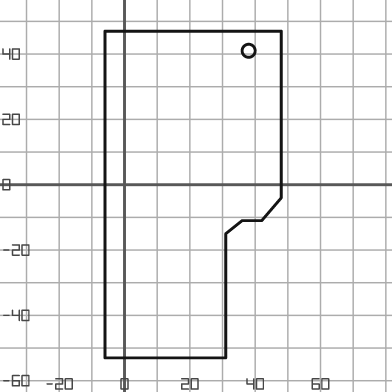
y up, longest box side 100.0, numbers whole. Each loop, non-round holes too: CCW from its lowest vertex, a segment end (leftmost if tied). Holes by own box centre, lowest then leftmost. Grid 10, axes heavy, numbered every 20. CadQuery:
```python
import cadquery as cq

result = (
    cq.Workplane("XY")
    .moveTo(-6.0, -53.0)
    .lineTo(31.0, -53.0)
    .lineTo(31.0, -15.0)
    .lineTo(36.0, -11.0)
    .lineTo(42.0, -11.0)
    .lineTo(48.0, -4.0)
    .lineTo(48.0, 47.0)
    .lineTo(-6.0, 47.0)
    .close()
    .moveTo(38.0, 41.0)
    .circle(2.0)
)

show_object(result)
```